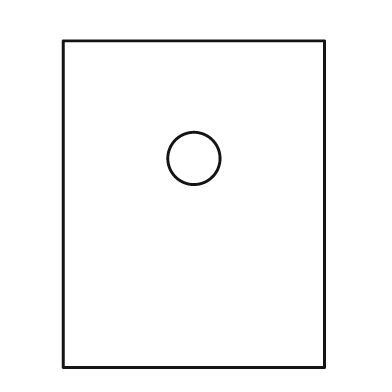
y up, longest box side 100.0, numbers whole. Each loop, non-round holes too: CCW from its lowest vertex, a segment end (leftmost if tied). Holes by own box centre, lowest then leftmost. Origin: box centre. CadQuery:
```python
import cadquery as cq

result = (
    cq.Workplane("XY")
    .moveTo(-40.0, -50.0)
    .lineTo(40.0, -50.0)
    .lineTo(40.0, 50.0)
    .lineTo(-40.0, 50.0)
    .close()
    .moveTo(0.0, 14.0)
    .circle(8.0)
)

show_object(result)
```